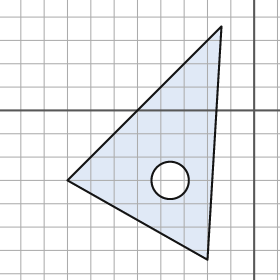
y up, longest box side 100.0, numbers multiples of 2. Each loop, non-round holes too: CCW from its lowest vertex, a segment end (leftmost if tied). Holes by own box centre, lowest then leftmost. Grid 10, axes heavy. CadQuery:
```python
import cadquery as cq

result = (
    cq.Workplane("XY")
    .moveTo(-20.0, -64.0)
    .lineTo(-14.0, 36.0)
    .lineTo(-80.0, -30.0)
    .close()
    .moveTo(-36.0, -30.0)
    .circle(8.0)
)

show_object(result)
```